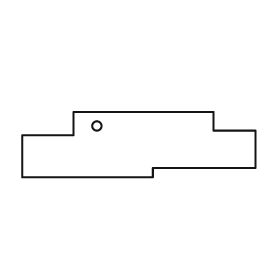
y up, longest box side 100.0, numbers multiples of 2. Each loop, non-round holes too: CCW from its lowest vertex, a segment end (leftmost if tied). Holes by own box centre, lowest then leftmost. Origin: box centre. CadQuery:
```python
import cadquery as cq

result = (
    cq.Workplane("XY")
    .moveTo(-50.0, -14.0)
    .lineTo(6.0, -14.0)
    .lineTo(6.0, -10.0)
    .lineTo(50.0, -10.0)
    .lineTo(50.0, 6.0)
    .lineTo(32.0, 6.0)
    .lineTo(32.0, 14.0)
    .lineTo(-28.0, 14.0)
    .lineTo(-28.0, 4.0)
    .lineTo(-50.0, 4.0)
    .close()
    .moveTo(-18.0, 8.0)
    .circle(2.0)
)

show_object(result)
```